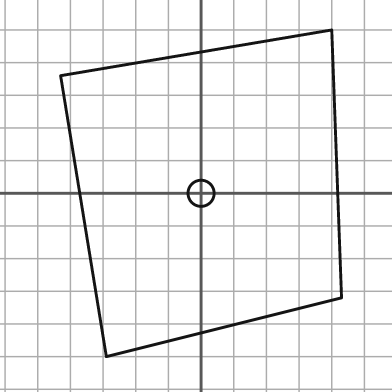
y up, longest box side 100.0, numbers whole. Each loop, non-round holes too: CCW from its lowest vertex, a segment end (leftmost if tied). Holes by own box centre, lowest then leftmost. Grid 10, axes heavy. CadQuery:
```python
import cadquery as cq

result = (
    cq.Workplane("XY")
    .moveTo(-29.0, -50.0)
    .lineTo(43.0, -32.0)
    .lineTo(40.0, 50.0)
    .lineTo(-43.0, 36.0)
    .close()
    .moveTo(0.0, 0.0)
    .circle(4.0)
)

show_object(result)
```